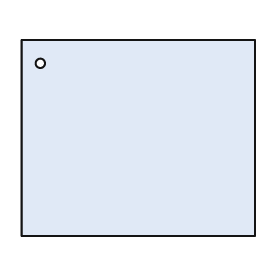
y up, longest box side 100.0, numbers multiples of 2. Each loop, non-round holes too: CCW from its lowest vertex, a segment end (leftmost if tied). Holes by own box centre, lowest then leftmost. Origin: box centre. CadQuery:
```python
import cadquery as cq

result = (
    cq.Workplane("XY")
    .moveTo(-50.0, -42.0)
    .lineTo(50.0, -42.0)
    .lineTo(50.0, 42.0)
    .lineTo(-50.0, 42.0)
    .close()
    .moveTo(-42.0, 32.0)
    .circle(2.0)
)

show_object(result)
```